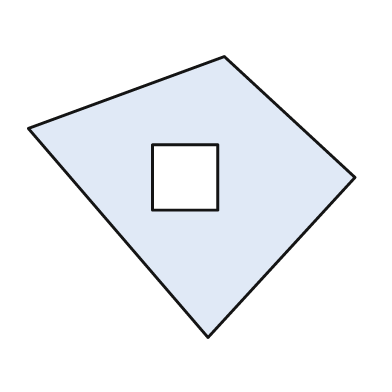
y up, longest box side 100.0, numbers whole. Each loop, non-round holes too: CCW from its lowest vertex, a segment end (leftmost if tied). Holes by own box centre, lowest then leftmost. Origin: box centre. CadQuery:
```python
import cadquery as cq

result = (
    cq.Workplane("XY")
    .moveTo(5.0, -43.0)
    .lineTo(50.0, 6.0)
    .lineTo(10.0, 43.0)
    .lineTo(-50.0, 21.0)
    .close()
    .moveTo(-12.0, -4.0)
    .lineTo(8.0, -4.0)
    .lineTo(8.0, 16.0)
    .lineTo(-12.0, 16.0)
    .close()
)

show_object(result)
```